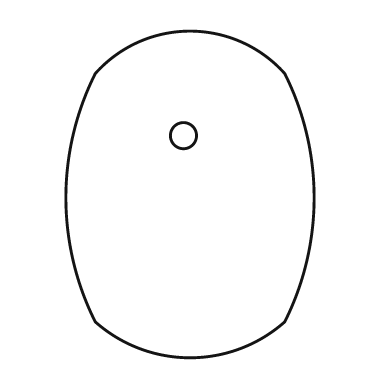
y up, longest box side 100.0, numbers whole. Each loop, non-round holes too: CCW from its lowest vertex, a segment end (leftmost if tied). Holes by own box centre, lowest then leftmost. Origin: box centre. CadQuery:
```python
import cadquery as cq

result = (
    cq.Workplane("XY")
    .moveTo(-29.0, -39.0)
    .threePointArc((0.0, -50.0), (29.0, -39.0))
    .threePointArc((38.0, -1.0), (29.0, 37.0))
    .threePointArc((0.0, 50.0), (-29.0, 37.0))
    .threePointArc((-38.0, -1.0), (-29.0, -39.0))
    .close()
    .moveTo(-2.0, 18.0)
    .circle(4.0)
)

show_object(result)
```